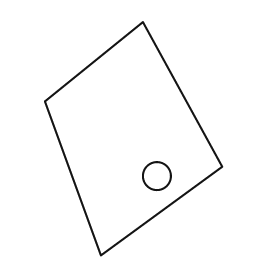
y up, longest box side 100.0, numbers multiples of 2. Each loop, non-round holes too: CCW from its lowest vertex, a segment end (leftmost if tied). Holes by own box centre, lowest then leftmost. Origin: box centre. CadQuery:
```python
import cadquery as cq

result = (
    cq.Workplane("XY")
    .moveTo(-14.0, -50.0)
    .lineTo(38.0, -12.0)
    .lineTo(4.0, 50.0)
    .lineTo(-38.0, 16.0)
    .close()
    .moveTo(10.0, -16.0)
    .circle(6.0)
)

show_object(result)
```